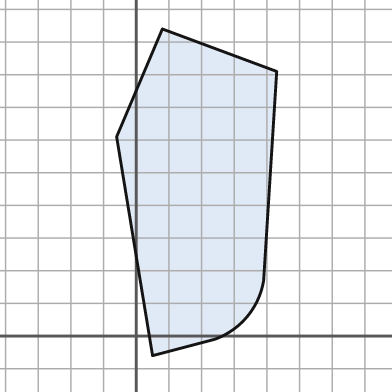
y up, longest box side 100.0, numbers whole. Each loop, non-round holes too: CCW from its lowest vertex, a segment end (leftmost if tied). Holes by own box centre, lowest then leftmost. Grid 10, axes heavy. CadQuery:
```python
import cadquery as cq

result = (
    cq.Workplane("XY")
    .moveTo(5.0, -6.0)
    .lineTo(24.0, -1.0)
    .threePointArc((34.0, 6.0), (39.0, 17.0))
    .lineTo(43.0, 81.0)
    .lineTo(8.0, 94.0)
    .lineTo(-6.0, 61.0)
    .close()
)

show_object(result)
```